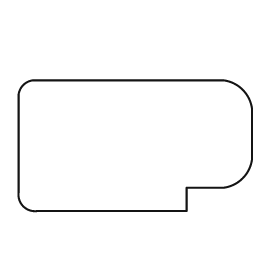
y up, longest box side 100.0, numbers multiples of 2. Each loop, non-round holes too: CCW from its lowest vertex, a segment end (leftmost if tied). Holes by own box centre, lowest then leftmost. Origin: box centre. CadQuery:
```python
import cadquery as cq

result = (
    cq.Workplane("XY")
    .moveTo(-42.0, -28.0)
    .lineTo(22.0, -28.0)
    .lineTo(22.0, -18.0)
    .lineTo(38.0, -18.0)
    .threePointArc((46.0, -14.0), (50.0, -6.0))
    .lineTo(50.0, 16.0)
    .threePointArc((46.0, 24.0), (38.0, 28.0))
    .lineTo(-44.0, 28.0)
    .threePointArc((-48.0, 26.0), (-50.0, 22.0))
    .lineTo(-50.0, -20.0)
    .threePointArc((-48.0, -26.0), (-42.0, -28.0))
    .close()
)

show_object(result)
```